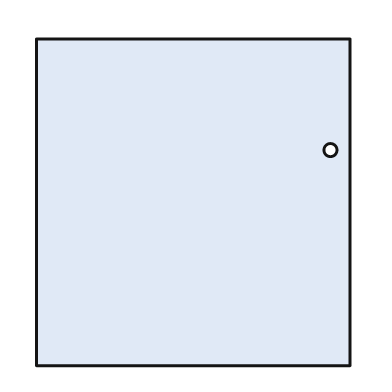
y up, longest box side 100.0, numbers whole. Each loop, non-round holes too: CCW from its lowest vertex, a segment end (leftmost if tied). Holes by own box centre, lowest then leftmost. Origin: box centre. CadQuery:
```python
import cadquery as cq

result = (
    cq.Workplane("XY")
    .moveTo(-48.0, -50.0)
    .lineTo(48.0, -50.0)
    .lineTo(48.0, 50.0)
    .lineTo(-48.0, 50.0)
    .close()
    .moveTo(42.0, 16.0)
    .circle(2.0)
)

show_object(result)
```